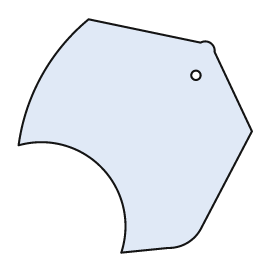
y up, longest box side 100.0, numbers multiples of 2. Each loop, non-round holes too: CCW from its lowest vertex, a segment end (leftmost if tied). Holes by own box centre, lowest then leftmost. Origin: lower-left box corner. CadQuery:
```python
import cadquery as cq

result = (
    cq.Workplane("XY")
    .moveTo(44.0, 0.0)
    .lineTo(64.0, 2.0)
    .threePointArc((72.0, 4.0), (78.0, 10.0))
    .lineTo(100.0, 52.0)
    .lineTo(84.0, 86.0)
    .threePointArc((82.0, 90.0), (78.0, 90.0))
    .lineTo(30.0, 100.0)
    .threePointArc((10.0, 76.0), (0.0, 46.0))
    .threePointArc((36.0, 36.0), (44.0, 0.0))
    .close()
    .moveTo(76.0, 76.0)
    .circle(2.0)
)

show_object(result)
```